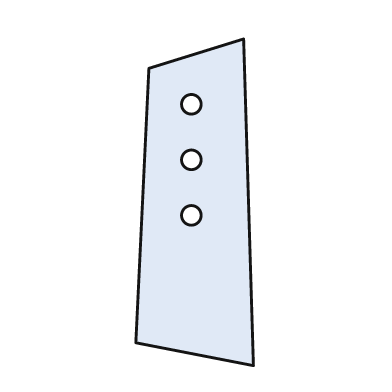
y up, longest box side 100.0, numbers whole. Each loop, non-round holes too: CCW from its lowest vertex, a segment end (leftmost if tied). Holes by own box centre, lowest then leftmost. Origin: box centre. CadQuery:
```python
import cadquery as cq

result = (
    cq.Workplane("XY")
    .moveTo(18.0, -50.0)
    .lineTo(15.0, 50.0)
    .lineTo(-14.0, 41.0)
    .lineTo(-18.0, -43.0)
    .close()
    .moveTo(-1.0, -4.0)
    .circle(3.0)
    .moveTo(-1.0, 13.0)
    .circle(3.0)
    .moveTo(-1.0, 30.0)
    .circle(3.0)
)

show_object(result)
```